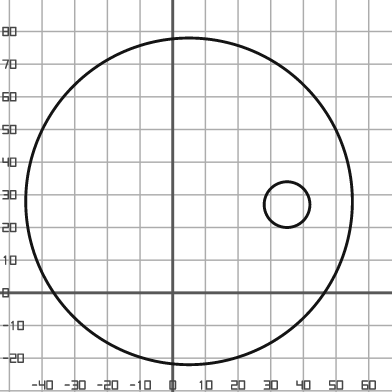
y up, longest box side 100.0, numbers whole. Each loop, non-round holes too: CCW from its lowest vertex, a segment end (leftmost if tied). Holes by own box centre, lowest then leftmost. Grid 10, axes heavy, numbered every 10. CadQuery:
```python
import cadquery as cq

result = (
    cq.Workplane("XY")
    .moveTo(5.0, 28.0)
    .circle(50.0)
    .moveTo(35.0, 27.0)
    .circle(7.0)
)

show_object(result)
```